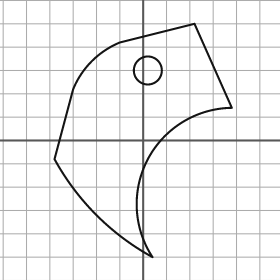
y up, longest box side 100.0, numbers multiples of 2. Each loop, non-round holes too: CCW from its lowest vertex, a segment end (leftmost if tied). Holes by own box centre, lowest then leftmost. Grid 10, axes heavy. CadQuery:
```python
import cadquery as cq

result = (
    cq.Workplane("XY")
    .moveTo(4.0, -50.0)
    .threePointArc((2.0, -8.0), (38.0, 14.0))
    .lineTo(22.0, 50.0)
    .lineTo(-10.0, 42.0)
    .threePointArc((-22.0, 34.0), (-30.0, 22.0))
    .lineTo(-38.0, -8.0)
    .threePointArc((-20.0, -32.0), (4.0, -50.0))
    .close()
    .moveTo(2.0, 30.0)
    .circle(6.0)
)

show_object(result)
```